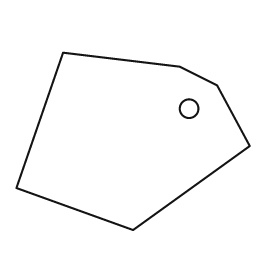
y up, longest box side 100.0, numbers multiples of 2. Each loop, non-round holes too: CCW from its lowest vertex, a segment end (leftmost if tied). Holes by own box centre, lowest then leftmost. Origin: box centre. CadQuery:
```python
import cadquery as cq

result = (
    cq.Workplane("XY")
    .moveTo(0.0, -38.0)
    .lineTo(50.0, -2.0)
    .lineTo(36.0, 24.0)
    .lineTo(20.0, 32.0)
    .lineTo(-30.0, 38.0)
    .lineTo(-50.0, -20.0)
    .close()
    .moveTo(24.0, 14.0)
    .circle(4.0)
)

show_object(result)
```